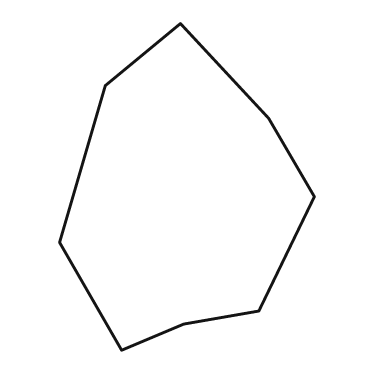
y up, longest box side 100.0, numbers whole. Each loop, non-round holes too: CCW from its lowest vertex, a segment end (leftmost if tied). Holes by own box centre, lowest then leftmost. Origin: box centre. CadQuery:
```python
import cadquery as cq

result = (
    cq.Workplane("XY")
    .moveTo(-20.0, -50.0)
    .lineTo(-1.0, -42.0)
    .lineTo(22.0, -38.0)
    .lineTo(39.0, -3.0)
    .lineTo(25.0, 21.0)
    .lineTo(-2.0, 50.0)
    .lineTo(-25.0, 31.0)
    .lineTo(-39.0, -17.0)
    .close()
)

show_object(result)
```